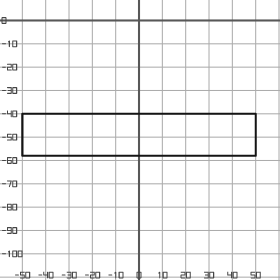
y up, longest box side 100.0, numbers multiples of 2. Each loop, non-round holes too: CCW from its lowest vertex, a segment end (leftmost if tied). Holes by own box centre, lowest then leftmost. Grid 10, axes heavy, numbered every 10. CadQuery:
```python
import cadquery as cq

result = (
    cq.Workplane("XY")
    .moveTo(-50.0, -58.0)
    .lineTo(50.0, -58.0)
    .lineTo(50.0, -40.0)
    .lineTo(-50.0, -40.0)
    .close()
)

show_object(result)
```